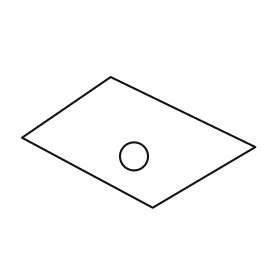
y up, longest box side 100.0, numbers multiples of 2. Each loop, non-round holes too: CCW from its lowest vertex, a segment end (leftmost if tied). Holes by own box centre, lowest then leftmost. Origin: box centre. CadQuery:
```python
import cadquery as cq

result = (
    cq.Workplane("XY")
    .moveTo(6.0, -28.0)
    .lineTo(50.0, -2.0)
    .lineTo(-12.0, 28.0)
    .lineTo(-50.0, 2.0)
    .close()
    .moveTo(-2.0, -6.0)
    .circle(6.0)
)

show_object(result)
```